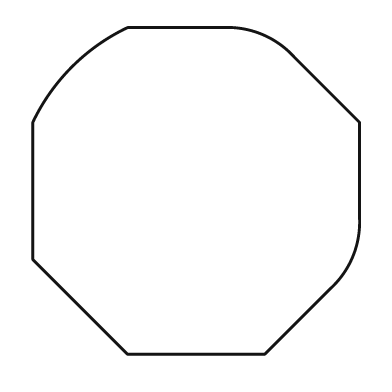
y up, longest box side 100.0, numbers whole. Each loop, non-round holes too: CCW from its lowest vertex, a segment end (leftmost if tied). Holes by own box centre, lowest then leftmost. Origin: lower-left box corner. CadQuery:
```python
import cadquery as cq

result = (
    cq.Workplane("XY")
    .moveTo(29.0, 0.0)
    .lineTo(71.0, 0.0)
    .lineTo(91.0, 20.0)
    .threePointArc((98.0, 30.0), (100.0, 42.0))
    .lineTo(100.0, 71.0)
    .lineTo(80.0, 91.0)
    .threePointArc((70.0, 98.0), (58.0, 100.0))
    .lineTo(29.0, 100.0)
    .threePointArc((12.0, 88.0), (0.0, 71.0))
    .lineTo(0.0, 29.0)
    .close()
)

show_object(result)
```